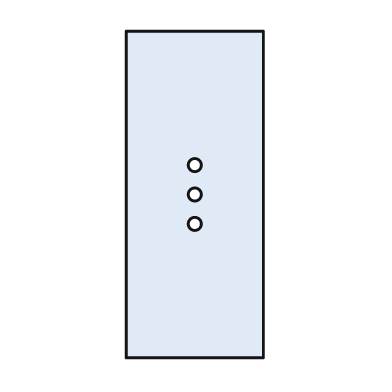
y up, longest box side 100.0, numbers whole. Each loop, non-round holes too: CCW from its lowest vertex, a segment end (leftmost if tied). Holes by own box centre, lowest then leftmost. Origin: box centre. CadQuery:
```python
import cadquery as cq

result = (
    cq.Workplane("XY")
    .moveTo(-21.0, -50.0)
    .lineTo(21.0, -50.0)
    .lineTo(21.0, 50.0)
    .lineTo(-21.0, 50.0)
    .close()
    .moveTo(0.0, -9.0)
    .circle(2.0)
    .moveTo(0.0, 0.0)
    .circle(2.0)
    .moveTo(0.0, 9.0)
    .circle(2.0)
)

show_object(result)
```